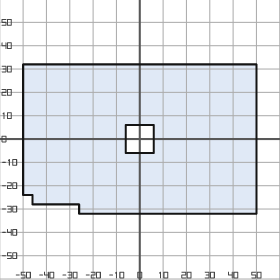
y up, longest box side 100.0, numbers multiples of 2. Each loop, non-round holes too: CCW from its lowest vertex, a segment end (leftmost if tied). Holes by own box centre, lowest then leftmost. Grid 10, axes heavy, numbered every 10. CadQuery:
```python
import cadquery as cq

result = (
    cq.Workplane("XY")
    .moveTo(-26.0, -32.0)
    .lineTo(50.0, -32.0)
    .lineTo(50.0, 32.0)
    .lineTo(-50.0, 32.0)
    .lineTo(-50.0, -24.0)
    .lineTo(-46.0, -24.0)
    .lineTo(-46.0, -28.0)
    .lineTo(-26.0, -28.0)
    .close()
    .moveTo(-6.0, -6.0)
    .lineTo(6.0, -6.0)
    .lineTo(6.0, 6.0)
    .lineTo(-6.0, 6.0)
    .close()
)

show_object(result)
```